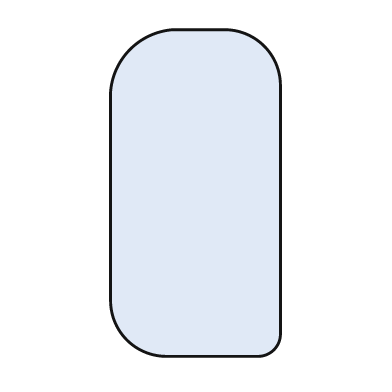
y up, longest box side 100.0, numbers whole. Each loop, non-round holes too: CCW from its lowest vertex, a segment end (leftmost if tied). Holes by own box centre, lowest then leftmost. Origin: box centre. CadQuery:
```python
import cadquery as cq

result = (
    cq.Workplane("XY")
    .moveTo(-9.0, -50.0)
    .lineTo(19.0, -50.0)
    .threePointArc((24.0, -48.0), (26.0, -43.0))
    .lineTo(26.0, 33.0)
    .threePointArc((21.0, 45.0), (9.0, 50.0))
    .lineTo(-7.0, 50.0)
    .threePointArc((-20.0, 44.0), (-26.0, 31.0))
    .lineTo(-26.0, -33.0)
    .threePointArc((-21.0, -45.0), (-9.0, -50.0))
    .close()
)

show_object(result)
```